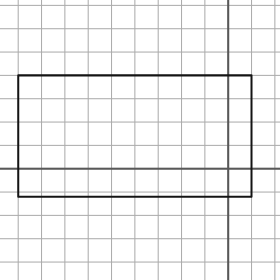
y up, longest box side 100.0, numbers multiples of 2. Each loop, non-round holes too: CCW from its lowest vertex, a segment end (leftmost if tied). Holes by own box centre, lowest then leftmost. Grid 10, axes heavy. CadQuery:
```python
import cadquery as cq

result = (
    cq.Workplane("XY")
    .moveTo(-90.0, -12.0)
    .lineTo(10.0, -12.0)
    .lineTo(10.0, 40.0)
    .lineTo(-90.0, 40.0)
    .close()
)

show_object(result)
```